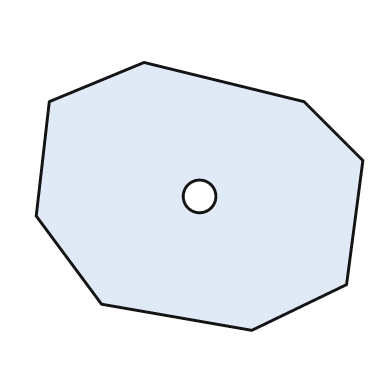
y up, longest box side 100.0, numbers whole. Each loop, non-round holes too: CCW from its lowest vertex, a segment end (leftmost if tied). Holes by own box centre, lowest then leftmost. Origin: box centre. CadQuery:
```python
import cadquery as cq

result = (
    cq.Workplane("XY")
    .moveTo(16.0, -41.0)
    .lineTo(45.0, -27.0)
    .lineTo(50.0, 11.0)
    .lineTo(32.0, 29.0)
    .lineTo(-17.0, 41.0)
    .lineTo(-46.0, 29.0)
    .lineTo(-50.0, -6.0)
    .lineTo(-30.0, -33.0)
    .close()
    .moveTo(0.0, 0.0)
    .circle(5.0)
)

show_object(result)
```